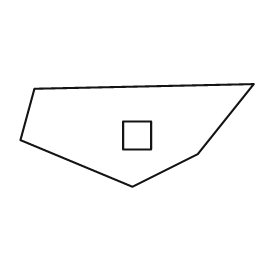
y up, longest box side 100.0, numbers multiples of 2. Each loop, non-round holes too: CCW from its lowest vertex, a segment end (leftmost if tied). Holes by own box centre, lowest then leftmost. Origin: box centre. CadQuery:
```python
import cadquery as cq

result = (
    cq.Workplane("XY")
    .moveTo(-2.0, -22.0)
    .lineTo(26.0, -8.0)
    .lineTo(50.0, 22.0)
    .lineTo(-44.0, 20.0)
    .lineTo(-50.0, -2.0)
    .close()
    .moveTo(-6.0, -6.0)
    .lineTo(6.0, -6.0)
    .lineTo(6.0, 6.0)
    .lineTo(-6.0, 6.0)
    .close()
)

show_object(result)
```